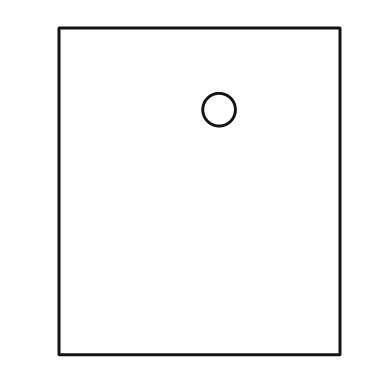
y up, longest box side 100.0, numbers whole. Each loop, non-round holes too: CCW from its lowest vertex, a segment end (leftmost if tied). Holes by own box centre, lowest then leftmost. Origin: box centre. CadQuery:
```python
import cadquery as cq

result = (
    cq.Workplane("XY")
    .moveTo(-43.0, -50.0)
    .lineTo(43.0, -50.0)
    .lineTo(43.0, 50.0)
    .lineTo(-43.0, 50.0)
    .close()
    .moveTo(6.0, 25.0)
    .circle(5.0)
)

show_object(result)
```